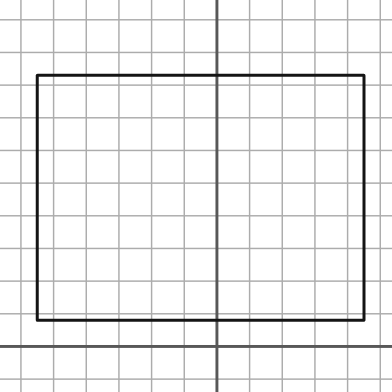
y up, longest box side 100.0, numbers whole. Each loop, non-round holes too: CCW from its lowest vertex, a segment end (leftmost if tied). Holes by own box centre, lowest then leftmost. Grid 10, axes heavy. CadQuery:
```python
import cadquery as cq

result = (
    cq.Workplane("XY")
    .moveTo(-55.0, 8.0)
    .lineTo(45.0, 8.0)
    .lineTo(45.0, 83.0)
    .lineTo(-55.0, 83.0)
    .close()
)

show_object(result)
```